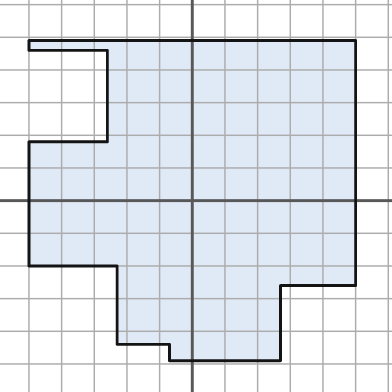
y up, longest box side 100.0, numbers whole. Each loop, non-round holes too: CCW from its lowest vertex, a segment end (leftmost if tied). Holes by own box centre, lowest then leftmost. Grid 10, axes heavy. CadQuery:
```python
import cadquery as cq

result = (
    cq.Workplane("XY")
    .moveTo(-7.0, -49.0)
    .lineTo(27.0, -49.0)
    .lineTo(27.0, -26.0)
    .lineTo(50.0, -26.0)
    .lineTo(50.0, 49.0)
    .lineTo(-50.0, 49.0)
    .lineTo(-50.0, 46.0)
    .lineTo(-26.0, 46.0)
    .lineTo(-26.0, 18.0)
    .lineTo(-50.0, 18.0)
    .lineTo(-50.0, -20.0)
    .lineTo(-23.0, -20.0)
    .lineTo(-23.0, -44.0)
    .lineTo(-7.0, -44.0)
    .close()
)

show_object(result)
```